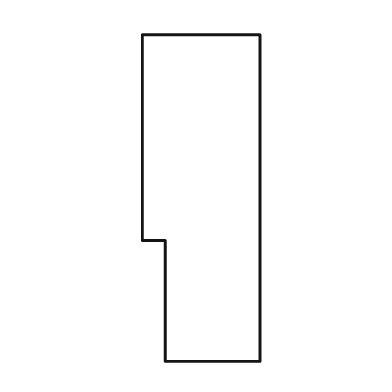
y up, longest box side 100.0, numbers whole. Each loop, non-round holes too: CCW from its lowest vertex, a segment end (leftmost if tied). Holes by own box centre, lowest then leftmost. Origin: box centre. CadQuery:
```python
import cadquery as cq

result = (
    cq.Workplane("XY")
    .moveTo(-11.0, -50.0)
    .lineTo(18.0, -50.0)
    .lineTo(18.0, 50.0)
    .lineTo(-18.0, 50.0)
    .lineTo(-18.0, -13.0)
    .lineTo(-11.0, -13.0)
    .close()
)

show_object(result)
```